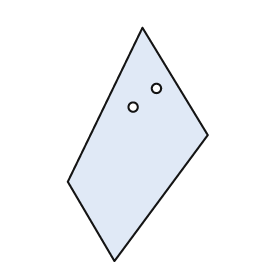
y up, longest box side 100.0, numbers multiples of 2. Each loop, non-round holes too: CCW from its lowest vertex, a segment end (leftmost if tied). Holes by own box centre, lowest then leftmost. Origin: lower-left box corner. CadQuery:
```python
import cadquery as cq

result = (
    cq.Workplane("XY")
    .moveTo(20.0, 0.0)
    .lineTo(60.0, 54.0)
    .lineTo(32.0, 100.0)
    .lineTo(0.0, 34.0)
    .close()
    .moveTo(28.0, 66.0)
    .circle(2.0)
    .moveTo(38.0, 74.0)
    .circle(2.0)
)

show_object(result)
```